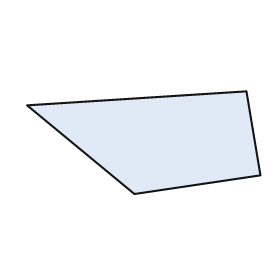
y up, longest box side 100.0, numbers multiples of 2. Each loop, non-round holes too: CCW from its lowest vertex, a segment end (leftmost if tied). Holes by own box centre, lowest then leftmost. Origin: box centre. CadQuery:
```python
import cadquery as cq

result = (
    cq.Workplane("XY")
    .moveTo(-4.0, -22.0)
    .lineTo(50.0, -14.0)
    .lineTo(44.0, 22.0)
    .lineTo(-50.0, 16.0)
    .close()
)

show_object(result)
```